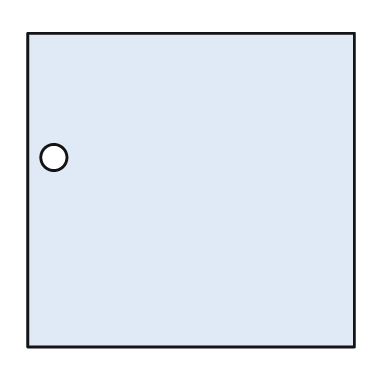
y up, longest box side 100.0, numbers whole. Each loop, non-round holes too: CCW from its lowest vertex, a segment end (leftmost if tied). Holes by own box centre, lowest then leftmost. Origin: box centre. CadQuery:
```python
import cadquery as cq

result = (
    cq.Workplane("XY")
    .moveTo(-50.0, -48.0)
    .lineTo(50.0, -48.0)
    .lineTo(50.0, 48.0)
    .lineTo(-50.0, 48.0)
    .close()
    .moveTo(-42.0, 10.0)
    .circle(4.0)
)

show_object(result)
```